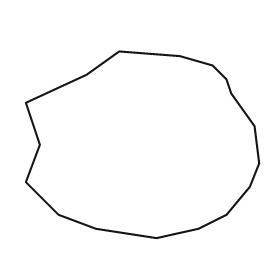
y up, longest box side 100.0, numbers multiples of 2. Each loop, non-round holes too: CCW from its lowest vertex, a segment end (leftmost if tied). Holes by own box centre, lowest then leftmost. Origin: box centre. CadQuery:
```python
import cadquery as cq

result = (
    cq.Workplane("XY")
    .moveTo(6.0, -40.0)
    .lineTo(24.0, -36.0)
    .lineTo(36.0, -30.0)
    .lineTo(46.0, -18.0)
    .lineTo(50.0, -8.0)
    .lineTo(48.0, 8.0)
    .lineTo(38.0, 22.0)
    .lineTo(36.0, 28.0)
    .lineTo(30.0, 34.0)
    .lineTo(16.0, 38.0)
    .lineTo(-10.0, 40.0)
    .lineTo(-24.0, 30.0)
    .lineTo(-50.0, 18.0)
    .lineTo(-44.0, 0.0)
    .lineTo(-50.0, -16.0)
    .lineTo(-36.0, -30.0)
    .lineTo(-20.0, -36.0)
    .close()
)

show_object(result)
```